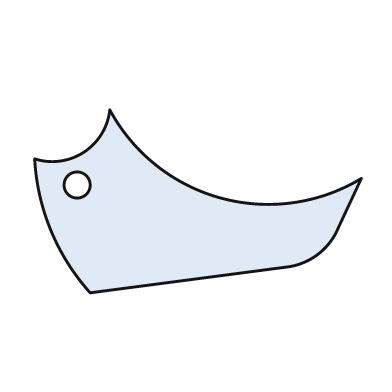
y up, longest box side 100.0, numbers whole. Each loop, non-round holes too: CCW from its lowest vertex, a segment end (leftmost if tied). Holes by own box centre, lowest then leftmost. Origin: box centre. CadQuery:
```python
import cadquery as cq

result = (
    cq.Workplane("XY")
    .moveTo(-33.0, -28.0)
    .lineTo(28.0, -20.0)
    .threePointArc((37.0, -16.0), (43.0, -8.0))
    .lineTo(50.0, 7.0)
    .threePointArc((7.0, 1.0), (-27.0, 28.0))
    .threePointArc((-35.0, 15.0), (-50.0, 13.0))
    .threePointArc((-45.0, -9.0), (-33.0, -28.0))
    .close()
    .moveTo(-37.0, 5.0)
    .circle(4.0)
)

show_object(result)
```